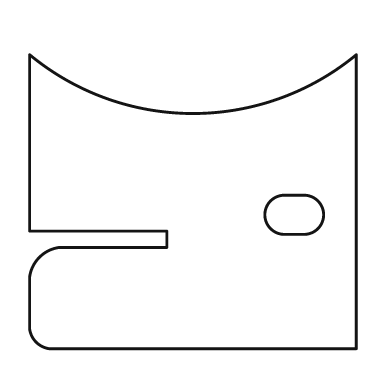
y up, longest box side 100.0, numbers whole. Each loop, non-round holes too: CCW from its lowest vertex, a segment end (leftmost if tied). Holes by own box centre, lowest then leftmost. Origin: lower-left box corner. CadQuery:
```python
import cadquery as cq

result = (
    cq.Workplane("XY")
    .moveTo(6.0, 0.0)
    .lineTo(100.0, 0.0)
    .lineTo(100.0, 90.0)
    .threePointArc((50.0, 72.0), (0.0, 90.0))
    .lineTo(0.0, 36.0)
    .lineTo(42.0, 36.0)
    .lineTo(42.0, 31.0)
    .lineTo(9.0, 31.0)
    .threePointArc((3.0, 28.0), (0.0, 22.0))
    .lineTo(0.0, 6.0)
    .threePointArc((2.0, 2.0), (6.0, 0.0))
    .close()
    .moveTo(78.0, 35.0)
    .lineTo(84.0, 35.0)
    .threePointArc((90.0, 41.0), (84.0, 47.0))
    .lineTo(78.0, 47.0)
    .threePointArc((72.0, 41.0), (78.0, 35.0))
    .close()
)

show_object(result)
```